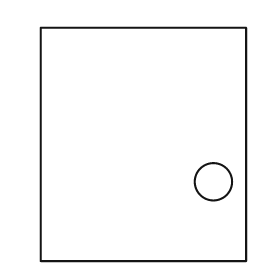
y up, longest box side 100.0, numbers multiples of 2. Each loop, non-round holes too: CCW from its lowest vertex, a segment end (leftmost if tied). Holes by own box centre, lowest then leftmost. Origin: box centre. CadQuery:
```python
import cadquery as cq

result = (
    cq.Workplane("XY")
    .moveTo(-44.0, -50.0)
    .lineTo(44.0, -50.0)
    .lineTo(44.0, 50.0)
    .lineTo(-44.0, 50.0)
    .close()
    .moveTo(30.0, -16.0)
    .circle(8.0)
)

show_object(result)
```